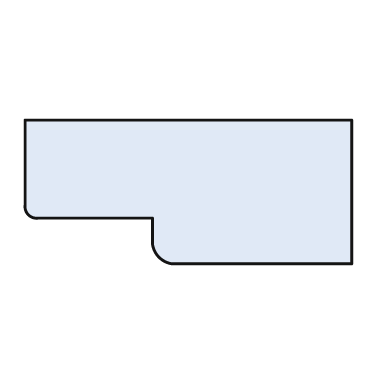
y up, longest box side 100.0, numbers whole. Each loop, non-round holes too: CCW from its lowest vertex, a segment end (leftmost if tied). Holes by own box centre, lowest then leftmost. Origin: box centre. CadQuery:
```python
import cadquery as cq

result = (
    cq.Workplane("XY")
    .moveTo(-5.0, -22.0)
    .lineTo(50.0, -22.0)
    .lineTo(50.0, 22.0)
    .lineTo(-50.0, 22.0)
    .lineTo(-50.0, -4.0)
    .threePointArc((-49.0, -7.0), (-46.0, -8.0))
    .lineTo(-11.0, -8.0)
    .lineTo(-11.0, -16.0)
    .threePointArc((-9.0, -20.0), (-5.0, -22.0))
    .close()
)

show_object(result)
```